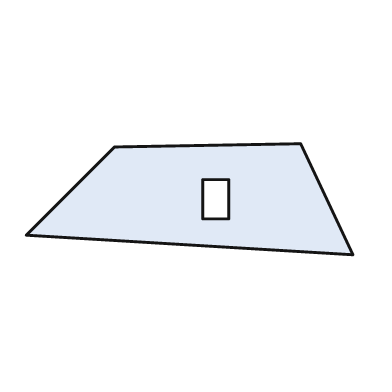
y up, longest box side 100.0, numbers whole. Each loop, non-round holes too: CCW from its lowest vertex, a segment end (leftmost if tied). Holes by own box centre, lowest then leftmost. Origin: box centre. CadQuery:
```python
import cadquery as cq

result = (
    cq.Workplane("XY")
    .moveTo(50.0, -17.0)
    .lineTo(34.0, 17.0)
    .lineTo(-23.0, 16.0)
    .lineTo(-50.0, -11.0)
    .close()
    .moveTo(4.0, -6.0)
    .lineTo(12.0, -6.0)
    .lineTo(12.0, 6.0)
    .lineTo(4.0, 6.0)
    .close()
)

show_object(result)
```